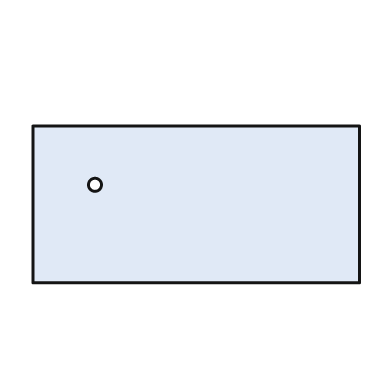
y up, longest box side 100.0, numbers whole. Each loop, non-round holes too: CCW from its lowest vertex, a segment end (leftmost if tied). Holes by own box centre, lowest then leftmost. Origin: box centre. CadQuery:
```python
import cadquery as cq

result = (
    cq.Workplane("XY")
    .moveTo(-50.0, -24.0)
    .lineTo(50.0, -24.0)
    .lineTo(50.0, 24.0)
    .lineTo(-50.0, 24.0)
    .close()
    .moveTo(-31.0, 6.0)
    .circle(2.0)
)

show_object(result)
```